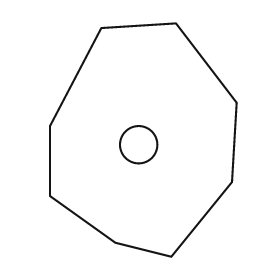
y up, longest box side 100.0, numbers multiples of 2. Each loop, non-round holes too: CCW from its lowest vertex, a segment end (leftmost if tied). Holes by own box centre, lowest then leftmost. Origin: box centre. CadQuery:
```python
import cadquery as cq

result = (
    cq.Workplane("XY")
    .moveTo(12.0, -50.0)
    .lineTo(38.0, -18.0)
    .lineTo(40.0, 16.0)
    .lineTo(14.0, 50.0)
    .lineTo(-18.0, 48.0)
    .lineTo(-40.0, 6.0)
    .lineTo(-40.0, -24.0)
    .lineTo(-12.0, -44.0)
    .close()
    .moveTo(-2.0, -2.0)
    .circle(8.0)
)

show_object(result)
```